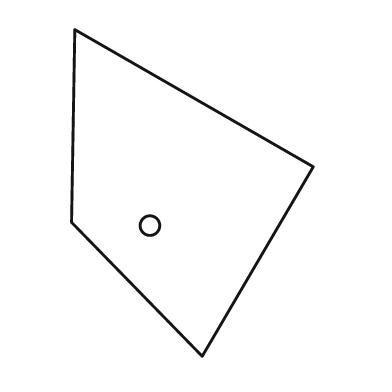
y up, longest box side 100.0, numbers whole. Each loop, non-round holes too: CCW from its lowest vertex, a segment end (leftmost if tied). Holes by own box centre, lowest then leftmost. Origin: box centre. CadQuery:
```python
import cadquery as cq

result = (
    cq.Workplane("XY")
    .moveTo(3.0, -50.0)
    .lineTo(37.0, 8.0)
    .lineTo(-36.0, 50.0)
    .lineTo(-37.0, -9.0)
    .close()
    .moveTo(-13.0, -10.0)
    .circle(3.0)
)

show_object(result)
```